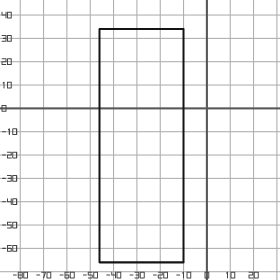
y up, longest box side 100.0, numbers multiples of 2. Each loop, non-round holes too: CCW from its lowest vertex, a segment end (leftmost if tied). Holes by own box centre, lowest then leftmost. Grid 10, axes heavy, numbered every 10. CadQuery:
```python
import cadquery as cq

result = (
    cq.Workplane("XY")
    .moveTo(-46.0, -66.0)
    .lineTo(-10.0, -66.0)
    .lineTo(-10.0, 34.0)
    .lineTo(-46.0, 34.0)
    .close()
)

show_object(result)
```